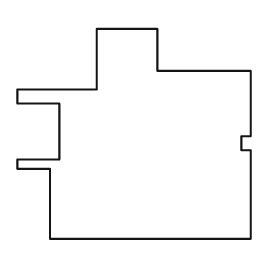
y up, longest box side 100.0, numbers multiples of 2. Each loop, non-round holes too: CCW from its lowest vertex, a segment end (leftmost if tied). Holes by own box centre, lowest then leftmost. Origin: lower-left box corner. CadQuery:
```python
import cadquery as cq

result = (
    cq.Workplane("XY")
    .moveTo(14.0, 0.0)
    .lineTo(100.0, 0.0)
    .lineTo(100.0, 38.0)
    .lineTo(96.0, 38.0)
    .lineTo(96.0, 44.0)
    .lineTo(100.0, 44.0)
    .lineTo(100.0, 72.0)
    .lineTo(60.0, 72.0)
    .lineTo(60.0, 90.0)
    .lineTo(34.0, 90.0)
    .lineTo(34.0, 64.0)
    .lineTo(0.0, 64.0)
    .lineTo(0.0, 58.0)
    .lineTo(18.0, 58.0)
    .lineTo(18.0, 34.0)
    .lineTo(0.0, 34.0)
    .lineTo(0.0, 30.0)
    .lineTo(14.0, 30.0)
    .close()
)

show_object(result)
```